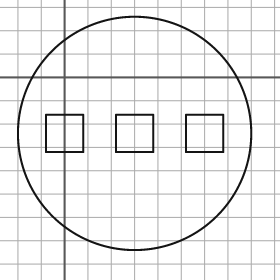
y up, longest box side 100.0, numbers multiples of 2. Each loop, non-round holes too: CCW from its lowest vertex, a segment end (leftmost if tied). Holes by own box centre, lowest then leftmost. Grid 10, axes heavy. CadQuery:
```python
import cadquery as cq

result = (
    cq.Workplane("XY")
    .moveTo(30.0, -24.0)
    .circle(50.0)
    .moveTo(-8.0, -32.0)
    .lineTo(8.0, -32.0)
    .lineTo(8.0, -16.0)
    .lineTo(-8.0, -16.0)
    .close()
    .moveTo(22.0, -32.0)
    .lineTo(38.0, -32.0)
    .lineTo(38.0, -16.0)
    .lineTo(22.0, -16.0)
    .close()
    .moveTo(52.0, -32.0)
    .lineTo(68.0, -32.0)
    .lineTo(68.0, -16.0)
    .lineTo(52.0, -16.0)
    .close()
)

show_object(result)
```